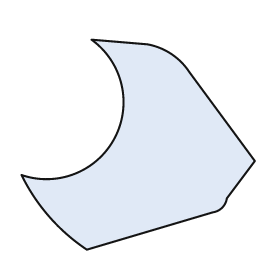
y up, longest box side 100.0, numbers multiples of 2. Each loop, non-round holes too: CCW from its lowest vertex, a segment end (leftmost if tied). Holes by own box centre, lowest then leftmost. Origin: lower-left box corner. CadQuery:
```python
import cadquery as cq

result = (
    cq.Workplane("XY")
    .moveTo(28.0, 0.0)
    .lineTo(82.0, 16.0)
    .threePointArc((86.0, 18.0), (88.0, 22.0))
    .lineTo(100.0, 38.0)
    .lineTo(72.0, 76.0)
    .threePointArc((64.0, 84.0), (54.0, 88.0))
    .lineTo(30.0, 90.0)
    .threePointArc((40.0, 48.0), (0.0, 32.0))
    .threePointArc((12.0, 14.0), (28.0, 0.0))
    .close()
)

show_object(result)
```